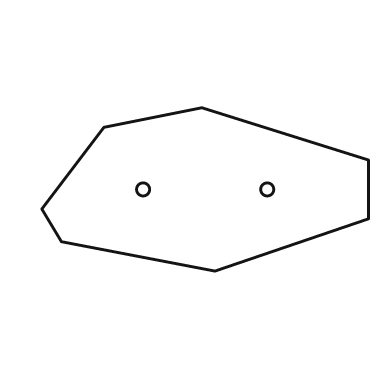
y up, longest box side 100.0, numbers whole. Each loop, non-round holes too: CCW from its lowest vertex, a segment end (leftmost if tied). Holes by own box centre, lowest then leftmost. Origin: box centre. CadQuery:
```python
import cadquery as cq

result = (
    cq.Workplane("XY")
    .moveTo(3.0, -25.0)
    .lineTo(50.0, -9.0)
    .lineTo(50.0, 9.0)
    .lineTo(-1.0, 25.0)
    .lineTo(-31.0, 19.0)
    .lineTo(-50.0, -6.0)
    .lineTo(-44.0, -16.0)
    .close()
    .moveTo(-19.0, 0.0)
    .circle(2.0)
    .moveTo(19.0, 0.0)
    .circle(2.0)
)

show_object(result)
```